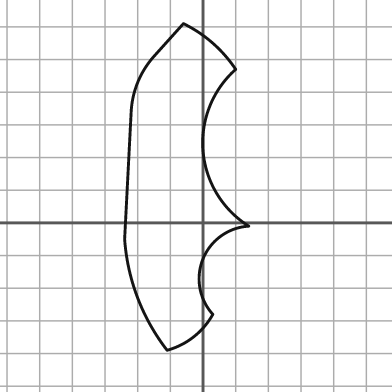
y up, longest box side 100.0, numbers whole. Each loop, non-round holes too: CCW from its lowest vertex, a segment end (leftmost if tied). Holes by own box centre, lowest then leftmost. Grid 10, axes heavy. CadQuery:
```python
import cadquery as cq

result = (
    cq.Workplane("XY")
    .moveTo(-11.0, -39.0)
    .threePointArc((-3.0, -35.0), (3.0, -28.0))
    .threePointArc((0.0, -11.0), (14.0, -1.0))
    .threePointArc((0.0, 22.0), (10.0, 47.0))
    .threePointArc((3.0, 55.0), (-6.0, 61.0))
    .lineTo(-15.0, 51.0)
    .threePointArc((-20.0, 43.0), (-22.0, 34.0))
    .lineTo(-24.0, -5.0)
    .threePointArc((-20.0, -23.0), (-11.0, -39.0))
    .close()
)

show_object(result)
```